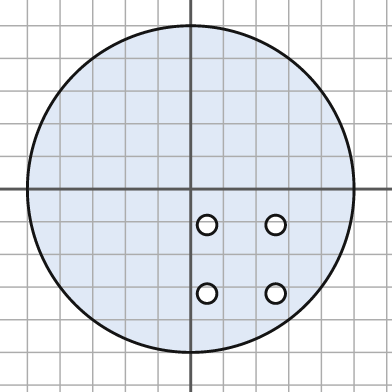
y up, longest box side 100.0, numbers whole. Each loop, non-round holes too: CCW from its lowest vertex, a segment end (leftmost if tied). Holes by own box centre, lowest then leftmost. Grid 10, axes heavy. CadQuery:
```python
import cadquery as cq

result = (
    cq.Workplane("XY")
    .moveTo(0.0, 0.0)
    .circle(50.0)
    .moveTo(5.0, -32.0)
    .circle(3.0)
    .moveTo(26.0, -32.0)
    .circle(3.0)
    .moveTo(5.0, -11.0)
    .circle(3.0)
    .moveTo(26.0, -11.0)
    .circle(3.0)
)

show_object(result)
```